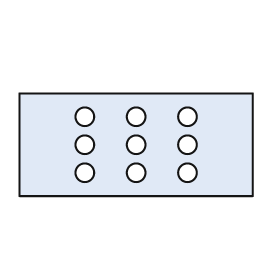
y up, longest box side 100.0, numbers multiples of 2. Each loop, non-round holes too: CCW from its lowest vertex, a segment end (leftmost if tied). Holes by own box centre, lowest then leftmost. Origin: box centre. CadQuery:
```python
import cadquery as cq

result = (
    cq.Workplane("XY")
    .moveTo(-50.0, -22.0)
    .lineTo(50.0, -22.0)
    .lineTo(50.0, 22.0)
    .lineTo(-50.0, 22.0)
    .close()
    .moveTo(-22.0, -12.0)
    .circle(4.0)
    .moveTo(0.0, -12.0)
    .circle(4.0)
    .moveTo(22.0, -12.0)
    .circle(4.0)
    .moveTo(-22.0, 0.0)
    .circle(4.0)
    .moveTo(0.0, 0.0)
    .circle(4.0)
    .moveTo(22.0, 0.0)
    .circle(4.0)
    .moveTo(-22.0, 12.0)
    .circle(4.0)
    .moveTo(0.0, 12.0)
    .circle(4.0)
    .moveTo(22.0, 12.0)
    .circle(4.0)
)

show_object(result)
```